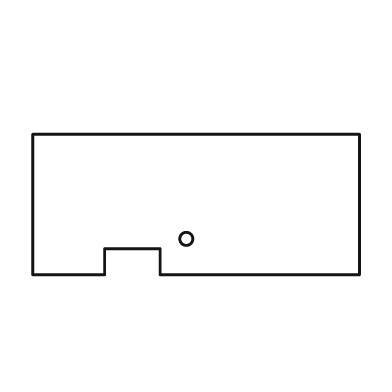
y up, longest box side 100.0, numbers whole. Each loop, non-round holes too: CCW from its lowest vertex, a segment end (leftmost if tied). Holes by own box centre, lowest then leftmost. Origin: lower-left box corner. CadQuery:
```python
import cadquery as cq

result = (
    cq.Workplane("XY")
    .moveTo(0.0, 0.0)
    .lineTo(22.0, 0.0)
    .lineTo(22.0, 8.0)
    .lineTo(39.0, 8.0)
    .lineTo(39.0, 0.0)
    .lineTo(100.0, 0.0)
    .lineTo(100.0, 43.0)
    .lineTo(0.0, 43.0)
    .close()
    .moveTo(47.0, 11.0)
    .circle(2.0)
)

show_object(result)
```